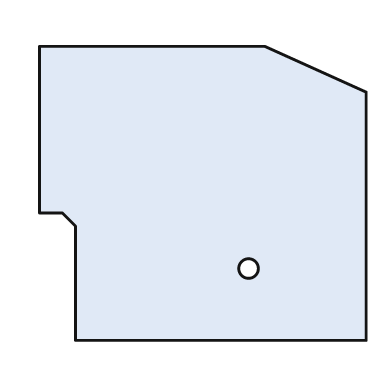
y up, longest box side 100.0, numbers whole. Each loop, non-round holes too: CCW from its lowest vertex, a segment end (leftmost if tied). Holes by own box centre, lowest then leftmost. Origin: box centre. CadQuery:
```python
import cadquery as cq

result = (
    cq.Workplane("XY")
    .moveTo(-39.0, -45.0)
    .lineTo(50.0, -45.0)
    .lineTo(50.0, 31.0)
    .lineTo(19.0, 45.0)
    .lineTo(-50.0, 45.0)
    .lineTo(-50.0, -6.0)
    .lineTo(-43.0, -6.0)
    .lineTo(-39.0, -10.0)
    .close()
    .moveTo(14.0, -23.0)
    .circle(3.0)
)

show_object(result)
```